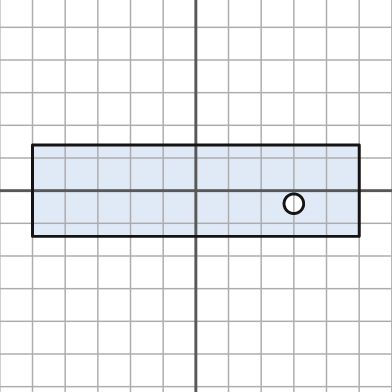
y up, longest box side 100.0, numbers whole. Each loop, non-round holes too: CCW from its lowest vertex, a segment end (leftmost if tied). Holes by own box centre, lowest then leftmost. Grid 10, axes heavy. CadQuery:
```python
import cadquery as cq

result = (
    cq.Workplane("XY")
    .moveTo(-50.0, -14.0)
    .lineTo(50.0, -14.0)
    .lineTo(50.0, 14.0)
    .lineTo(-50.0, 14.0)
    .close()
    .moveTo(30.0, -4.0)
    .circle(3.0)
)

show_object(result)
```